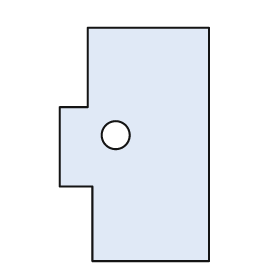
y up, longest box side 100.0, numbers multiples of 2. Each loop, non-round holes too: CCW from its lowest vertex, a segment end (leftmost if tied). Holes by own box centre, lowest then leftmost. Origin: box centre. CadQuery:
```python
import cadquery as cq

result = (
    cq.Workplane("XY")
    .moveTo(-18.0, -50.0)
    .lineTo(32.0, -50.0)
    .lineTo(32.0, 50.0)
    .lineTo(-20.0, 50.0)
    .lineTo(-20.0, 16.0)
    .lineTo(-32.0, 16.0)
    .lineTo(-32.0, -18.0)
    .lineTo(-18.0, -18.0)
    .close()
    .moveTo(-8.0, 4.0)
    .circle(6.0)
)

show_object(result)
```